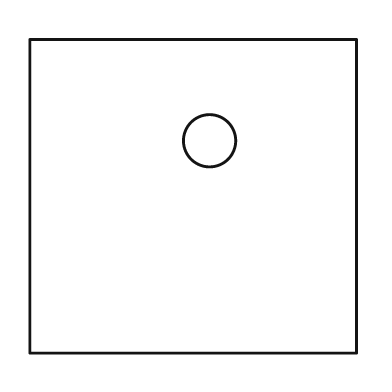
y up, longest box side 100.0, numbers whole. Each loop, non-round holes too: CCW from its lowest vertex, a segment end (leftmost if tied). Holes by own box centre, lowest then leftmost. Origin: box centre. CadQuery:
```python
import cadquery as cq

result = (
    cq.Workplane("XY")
    .moveTo(-50.0, -48.0)
    .lineTo(50.0, -48.0)
    .lineTo(50.0, 48.0)
    .lineTo(-50.0, 48.0)
    .close()
    .moveTo(5.0, 17.0)
    .circle(8.0)
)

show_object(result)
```